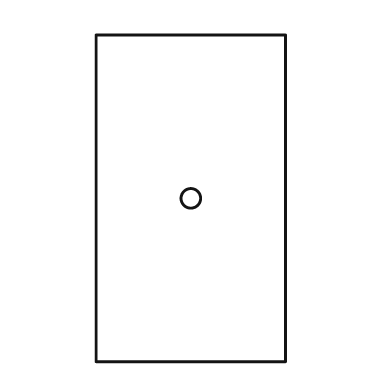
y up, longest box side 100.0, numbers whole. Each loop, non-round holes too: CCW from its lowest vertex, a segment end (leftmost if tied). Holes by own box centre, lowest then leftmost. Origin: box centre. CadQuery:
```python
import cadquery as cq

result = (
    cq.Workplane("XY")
    .moveTo(-29.0, -50.0)
    .lineTo(29.0, -50.0)
    .lineTo(29.0, 50.0)
    .lineTo(-29.0, 50.0)
    .close()
    .moveTo(0.0, 0.0)
    .circle(3.0)
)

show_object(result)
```